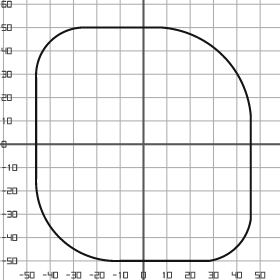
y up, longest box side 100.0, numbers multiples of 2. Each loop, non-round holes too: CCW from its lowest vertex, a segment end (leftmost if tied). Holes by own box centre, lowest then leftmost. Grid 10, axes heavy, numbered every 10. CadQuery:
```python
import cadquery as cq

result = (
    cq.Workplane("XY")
    .moveTo(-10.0, -50.0)
    .lineTo(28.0, -50.0)
    .threePointArc((40.0, -44.0), (46.0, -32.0))
    .lineTo(46.0, 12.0)
    .threePointArc((34.0, 38.0), (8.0, 50.0))
    .lineTo(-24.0, 50.0)
    .threePointArc((-40.0, 44.0), (-46.0, 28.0))
    .lineTo(-46.0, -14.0)
    .threePointArc((-36.0, -40.0), (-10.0, -50.0))
    .close()
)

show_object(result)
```